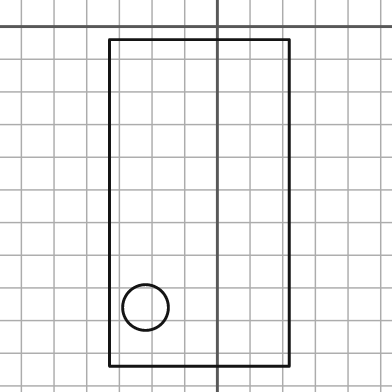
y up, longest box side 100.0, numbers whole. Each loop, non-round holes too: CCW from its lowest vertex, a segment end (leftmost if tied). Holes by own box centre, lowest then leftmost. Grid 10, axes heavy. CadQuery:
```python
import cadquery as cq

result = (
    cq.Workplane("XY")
    .moveTo(-33.0, -104.0)
    .lineTo(22.0, -104.0)
    .lineTo(22.0, -4.0)
    .lineTo(-33.0, -4.0)
    .close()
    .moveTo(-22.0, -86.0)
    .circle(7.0)
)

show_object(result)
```